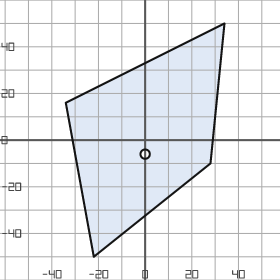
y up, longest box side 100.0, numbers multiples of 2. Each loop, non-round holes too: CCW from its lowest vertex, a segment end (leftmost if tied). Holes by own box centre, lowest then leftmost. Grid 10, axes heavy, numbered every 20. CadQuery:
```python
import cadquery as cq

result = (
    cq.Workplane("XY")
    .moveTo(-22.0, -50.0)
    .lineTo(28.0, -10.0)
    .lineTo(34.0, 50.0)
    .lineTo(-34.0, 16.0)
    .close()
    .moveTo(0.0, -6.0)
    .circle(2.0)
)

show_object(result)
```